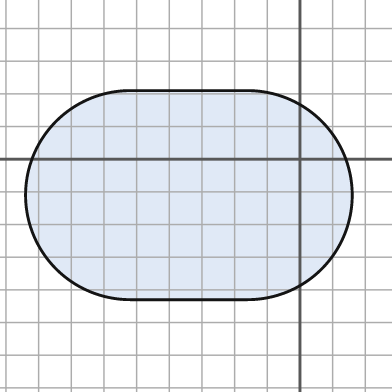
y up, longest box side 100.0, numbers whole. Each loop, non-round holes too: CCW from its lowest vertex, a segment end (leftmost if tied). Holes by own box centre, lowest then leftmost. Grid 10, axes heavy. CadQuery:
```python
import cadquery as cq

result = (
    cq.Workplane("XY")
    .moveTo(-52.0, -43.0)
    .lineTo(-16.0, -43.0)
    .threePointArc((16.0, -11.0), (-16.0, 21.0))
    .lineTo(-52.0, 21.0)
    .threePointArc((-84.0, -11.0), (-52.0, -43.0))
    .close()
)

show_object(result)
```